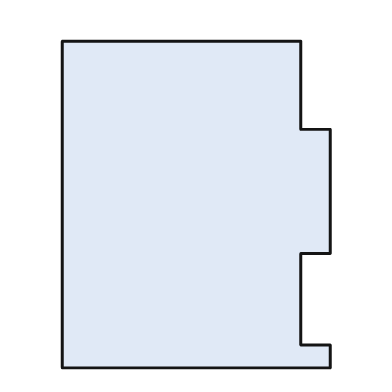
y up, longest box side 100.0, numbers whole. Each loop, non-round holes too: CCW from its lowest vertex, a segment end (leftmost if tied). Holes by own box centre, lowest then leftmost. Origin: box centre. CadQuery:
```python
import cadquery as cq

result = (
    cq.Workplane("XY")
    .moveTo(-41.0, -50.0)
    .lineTo(41.0, -50.0)
    .lineTo(41.0, -43.0)
    .lineTo(32.0, -43.0)
    .lineTo(32.0, -15.0)
    .lineTo(41.0, -15.0)
    .lineTo(41.0, 23.0)
    .lineTo(32.0, 23.0)
    .lineTo(32.0, 50.0)
    .lineTo(-41.0, 50.0)
    .close()
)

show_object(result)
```